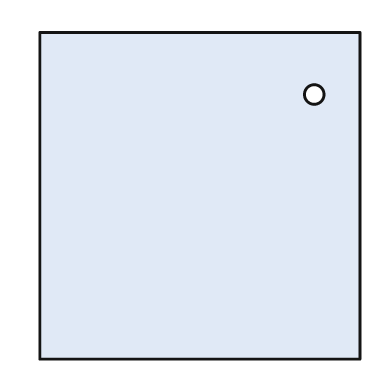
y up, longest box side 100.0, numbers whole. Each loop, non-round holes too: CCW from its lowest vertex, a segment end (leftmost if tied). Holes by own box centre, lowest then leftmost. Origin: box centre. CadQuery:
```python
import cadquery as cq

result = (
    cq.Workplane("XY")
    .moveTo(-49.0, -50.0)
    .lineTo(49.0, -50.0)
    .lineTo(49.0, 50.0)
    .lineTo(-49.0, 50.0)
    .close()
    .moveTo(35.0, 31.0)
    .circle(3.0)
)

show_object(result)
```